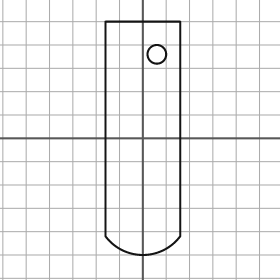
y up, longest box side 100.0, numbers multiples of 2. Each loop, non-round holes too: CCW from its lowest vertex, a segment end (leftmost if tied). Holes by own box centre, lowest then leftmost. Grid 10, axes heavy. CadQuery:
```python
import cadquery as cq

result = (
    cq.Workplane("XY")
    .moveTo(-16.0, -42.0)
    .threePointArc((0.0, -50.0), (16.0, -42.0))
    .lineTo(16.0, 50.0)
    .lineTo(-16.0, 50.0)
    .close()
    .moveTo(6.0, 36.0)
    .circle(4.0)
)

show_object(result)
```